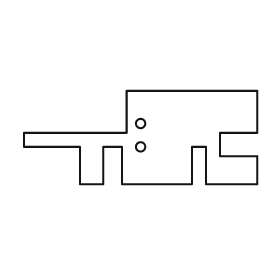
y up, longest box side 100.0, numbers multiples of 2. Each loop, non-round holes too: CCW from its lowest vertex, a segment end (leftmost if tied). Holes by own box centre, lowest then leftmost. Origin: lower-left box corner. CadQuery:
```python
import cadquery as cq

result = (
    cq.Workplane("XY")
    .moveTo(24.0, 0.0)
    .lineTo(34.0, 0.0)
    .lineTo(34.0, 16.0)
    .lineTo(42.0, 16.0)
    .lineTo(42.0, 0.0)
    .lineTo(72.0, 0.0)
    .lineTo(72.0, 16.0)
    .lineTo(78.0, 16.0)
    .lineTo(78.0, 0.0)
    .lineTo(100.0, 0.0)
    .lineTo(100.0, 12.0)
    .lineTo(84.0, 12.0)
    .lineTo(84.0, 22.0)
    .lineTo(100.0, 22.0)
    .lineTo(100.0, 40.0)
    .lineTo(44.0, 40.0)
    .lineTo(44.0, 22.0)
    .lineTo(0.0, 22.0)
    .lineTo(0.0, 16.0)
    .lineTo(24.0, 16.0)
    .close()
    .moveTo(50.0, 16.0)
    .circle(2.0)
    .moveTo(50.0, 26.0)
    .circle(2.0)
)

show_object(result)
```